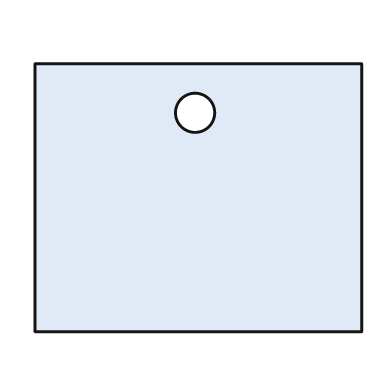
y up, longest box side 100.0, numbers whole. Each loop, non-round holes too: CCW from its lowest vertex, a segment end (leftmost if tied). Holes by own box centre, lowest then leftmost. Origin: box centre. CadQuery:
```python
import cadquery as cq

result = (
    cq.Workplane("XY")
    .moveTo(-50.0, -41.0)
    .lineTo(50.0, -41.0)
    .lineTo(50.0, 41.0)
    .lineTo(-50.0, 41.0)
    .close()
    .moveTo(-1.0, 26.0)
    .circle(6.0)
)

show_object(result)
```